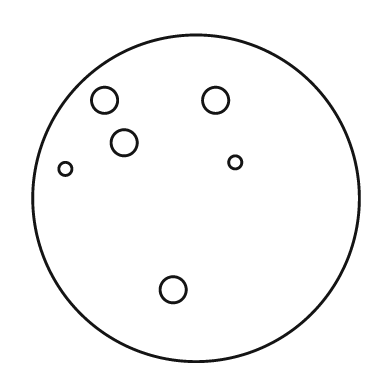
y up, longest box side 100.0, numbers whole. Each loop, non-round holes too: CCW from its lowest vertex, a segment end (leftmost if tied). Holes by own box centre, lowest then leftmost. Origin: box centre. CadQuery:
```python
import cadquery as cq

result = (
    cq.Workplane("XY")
    .moveTo(0.0, 0.0)
    .circle(50.0)
    .moveTo(-7.0, -28.0)
    .circle(4.0)
    .moveTo(-40.0, 9.0)
    .circle(2.0)
    .moveTo(12.0, 11.0)
    .circle(2.0)
    .moveTo(-22.0, 17.0)
    .circle(4.0)
    .moveTo(-28.0, 30.0)
    .circle(4.0)
    .moveTo(6.0, 30.0)
    .circle(4.0)
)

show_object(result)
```